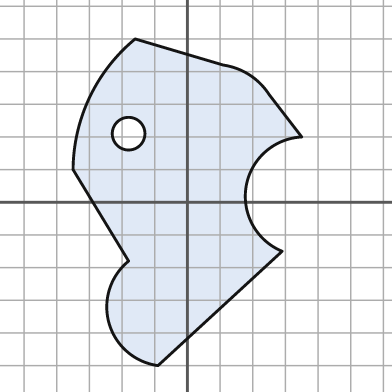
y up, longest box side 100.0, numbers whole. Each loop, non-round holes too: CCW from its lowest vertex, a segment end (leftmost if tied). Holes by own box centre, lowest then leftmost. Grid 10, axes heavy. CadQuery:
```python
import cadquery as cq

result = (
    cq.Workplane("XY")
    .moveTo(-9.0, -50.0)
    .lineTo(29.0, -15.0)
    .threePointArc((18.0, 5.0), (35.0, 20.0))
    .lineTo(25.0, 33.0)
    .threePointArc((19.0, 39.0), (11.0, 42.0))
    .lineTo(-16.0, 50.0)
    .threePointArc((-30.0, 32.0), (-35.0, 10.0))
    .lineTo(-18.0, -18.0)
    .threePointArc((-24.0, -37.0), (-9.0, -50.0))
    .close()
    .moveTo(-18.0, 21.0)
    .circle(5.0)
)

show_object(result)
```